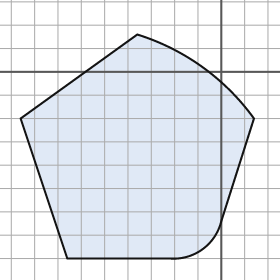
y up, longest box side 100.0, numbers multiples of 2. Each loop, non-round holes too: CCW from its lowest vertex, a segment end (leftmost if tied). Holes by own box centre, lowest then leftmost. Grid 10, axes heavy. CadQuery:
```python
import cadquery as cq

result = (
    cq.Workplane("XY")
    .moveTo(-66.0, -80.0)
    .lineTo(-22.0, -80.0)
    .threePointArc((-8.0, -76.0), (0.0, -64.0))
    .lineTo(14.0, -20.0)
    .threePointArc((-8.0, 2.0), (-36.0, 16.0))
    .lineTo(-86.0, -20.0)
    .close()
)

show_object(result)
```